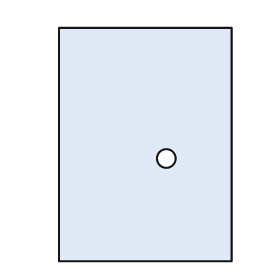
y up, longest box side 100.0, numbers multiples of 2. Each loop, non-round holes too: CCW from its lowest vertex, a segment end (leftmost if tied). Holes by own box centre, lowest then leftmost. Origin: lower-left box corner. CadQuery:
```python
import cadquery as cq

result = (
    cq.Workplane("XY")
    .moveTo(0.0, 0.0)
    .lineTo(74.0, 0.0)
    .lineTo(74.0, 100.0)
    .lineTo(0.0, 100.0)
    .close()
    .moveTo(46.0, 44.0)
    .circle(4.0)
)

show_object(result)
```